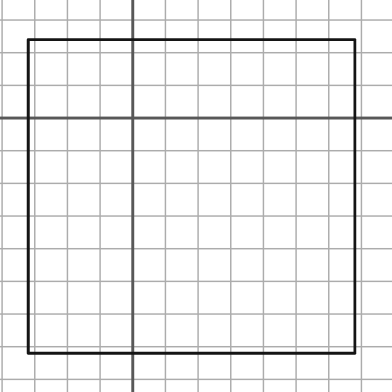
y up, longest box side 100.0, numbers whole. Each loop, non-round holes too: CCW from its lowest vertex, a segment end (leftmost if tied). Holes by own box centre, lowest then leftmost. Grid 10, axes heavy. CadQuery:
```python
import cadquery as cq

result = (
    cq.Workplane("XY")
    .moveTo(-32.0, -72.0)
    .lineTo(68.0, -72.0)
    .lineTo(68.0, 24.0)
    .lineTo(-32.0, 24.0)
    .close()
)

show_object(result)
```